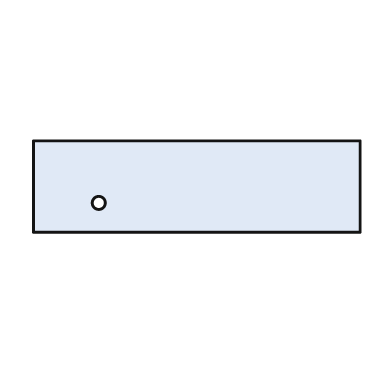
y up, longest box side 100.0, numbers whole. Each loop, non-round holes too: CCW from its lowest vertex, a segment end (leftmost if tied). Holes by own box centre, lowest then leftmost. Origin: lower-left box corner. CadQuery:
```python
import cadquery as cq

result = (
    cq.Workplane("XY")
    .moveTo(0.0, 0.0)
    .lineTo(100.0, 0.0)
    .lineTo(100.0, 28.0)
    .lineTo(0.0, 28.0)
    .close()
    .moveTo(20.0, 9.0)
    .circle(2.0)
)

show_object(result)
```